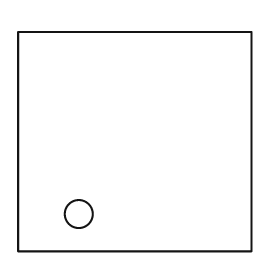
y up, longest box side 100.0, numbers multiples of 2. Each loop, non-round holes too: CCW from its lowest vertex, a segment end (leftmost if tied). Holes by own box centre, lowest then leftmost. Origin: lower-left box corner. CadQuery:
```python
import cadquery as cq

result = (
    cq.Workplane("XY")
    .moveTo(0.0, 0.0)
    .lineTo(100.0, 0.0)
    .lineTo(100.0, 94.0)
    .lineTo(0.0, 94.0)
    .close()
    .moveTo(26.0, 16.0)
    .circle(6.0)
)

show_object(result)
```